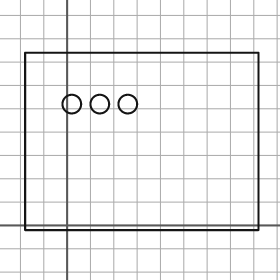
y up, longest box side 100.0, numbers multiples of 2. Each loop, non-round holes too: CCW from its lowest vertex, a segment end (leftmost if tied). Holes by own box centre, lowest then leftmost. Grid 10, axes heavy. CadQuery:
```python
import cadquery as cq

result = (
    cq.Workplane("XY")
    .moveTo(-18.0, -2.0)
    .lineTo(82.0, -2.0)
    .lineTo(82.0, 74.0)
    .lineTo(-18.0, 74.0)
    .close()
    .moveTo(2.0, 52.0)
    .circle(4.0)
    .moveTo(14.0, 52.0)
    .circle(4.0)
    .moveTo(26.0, 52.0)
    .circle(4.0)
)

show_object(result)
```